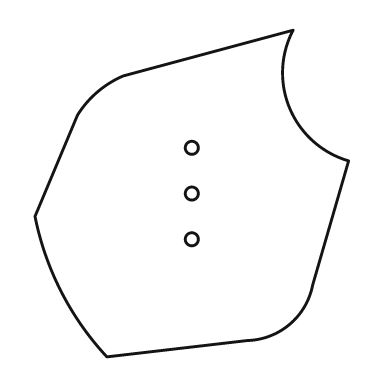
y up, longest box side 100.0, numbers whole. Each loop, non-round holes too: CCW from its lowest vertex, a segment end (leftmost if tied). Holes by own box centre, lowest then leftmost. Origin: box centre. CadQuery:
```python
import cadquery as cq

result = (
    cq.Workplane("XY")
    .moveTo(-26.0, -50.0)
    .lineTo(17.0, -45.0)
    .threePointArc((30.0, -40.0), (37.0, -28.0))
    .lineTo(48.0, 10.0)
    .threePointArc((30.0, 26.0), (31.0, 50.0))
    .lineTo(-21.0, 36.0)
    .threePointArc((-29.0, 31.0), (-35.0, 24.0))
    .lineTo(-48.0, -7.0)
    .threePointArc((-40.0, -30.0), (-26.0, -50.0))
    .close()
    .moveTo(0.0, -14.0)
    .circle(2.0)
    .moveTo(0.0, 0.0)
    .circle(2.0)
    .moveTo(0.0, 14.0)
    .circle(2.0)
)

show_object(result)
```